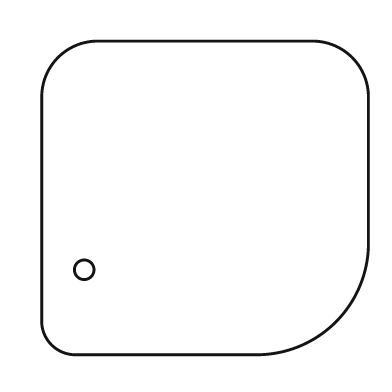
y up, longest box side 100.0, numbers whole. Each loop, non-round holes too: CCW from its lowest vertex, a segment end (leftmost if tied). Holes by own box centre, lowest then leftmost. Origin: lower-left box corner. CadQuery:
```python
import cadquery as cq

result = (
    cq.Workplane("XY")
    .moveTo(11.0, 0.0)
    .lineTo(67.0, 0.0)
    .threePointArc((90.0, 10.0), (100.0, 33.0))
    .lineTo(100.0, 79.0)
    .threePointArc((95.0, 91.0), (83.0, 96.0))
    .lineTo(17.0, 96.0)
    .threePointArc((5.0, 91.0), (0.0, 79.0))
    .lineTo(0.0, 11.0)
    .threePointArc((3.0, 3.0), (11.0, 0.0))
    .close()
    .moveTo(13.0, 26.0)
    .circle(3.0)
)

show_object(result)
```